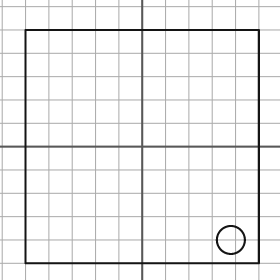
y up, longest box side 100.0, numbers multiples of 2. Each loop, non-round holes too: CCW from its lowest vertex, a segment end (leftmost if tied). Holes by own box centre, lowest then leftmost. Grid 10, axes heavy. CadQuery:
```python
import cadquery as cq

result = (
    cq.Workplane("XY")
    .moveTo(-50.0, -50.0)
    .lineTo(50.0, -50.0)
    .lineTo(50.0, 50.0)
    .lineTo(-50.0, 50.0)
    .close()
    .moveTo(38.0, -40.0)
    .circle(6.0)
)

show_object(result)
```